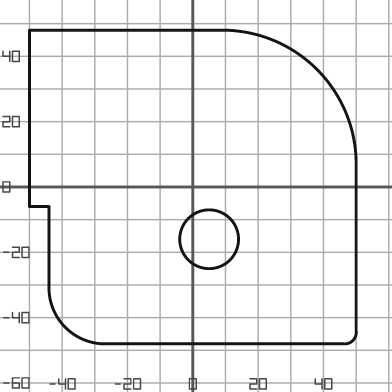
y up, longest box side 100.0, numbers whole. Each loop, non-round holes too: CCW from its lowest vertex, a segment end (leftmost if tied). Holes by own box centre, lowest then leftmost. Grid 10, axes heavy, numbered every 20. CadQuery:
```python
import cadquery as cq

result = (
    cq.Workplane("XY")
    .moveTo(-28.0, -48.0)
    .lineTo(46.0, -48.0)
    .threePointArc((49.0, -47.0), (50.0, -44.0))
    .lineTo(50.0, 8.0)
    .threePointArc((38.0, 36.0), (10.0, 48.0))
    .lineTo(-50.0, 48.0)
    .lineTo(-50.0, -6.0)
    .lineTo(-44.0, -6.0)
    .lineTo(-44.0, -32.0)
    .threePointArc((-39.0, -43.0), (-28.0, -48.0))
    .close()
    .moveTo(5.0, -16.0)
    .circle(9.0)
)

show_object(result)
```